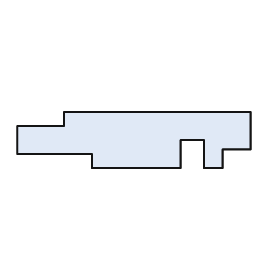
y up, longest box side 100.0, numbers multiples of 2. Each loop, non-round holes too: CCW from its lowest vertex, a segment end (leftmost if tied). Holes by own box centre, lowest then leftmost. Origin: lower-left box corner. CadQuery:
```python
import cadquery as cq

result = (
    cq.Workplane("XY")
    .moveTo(32.0, 0.0)
    .lineTo(70.0, 0.0)
    .lineTo(70.0, 12.0)
    .lineTo(80.0, 12.0)
    .lineTo(80.0, 0.0)
    .lineTo(88.0, 0.0)
    .lineTo(88.0, 8.0)
    .lineTo(100.0, 8.0)
    .lineTo(100.0, 24.0)
    .lineTo(20.0, 24.0)
    .lineTo(20.0, 18.0)
    .lineTo(0.0, 18.0)
    .lineTo(0.0, 6.0)
    .lineTo(32.0, 6.0)
    .close()
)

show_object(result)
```